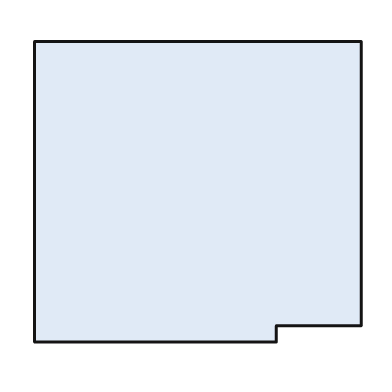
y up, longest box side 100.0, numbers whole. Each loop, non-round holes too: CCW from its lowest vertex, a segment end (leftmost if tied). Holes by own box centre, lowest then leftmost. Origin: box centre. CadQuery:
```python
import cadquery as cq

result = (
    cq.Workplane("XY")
    .moveTo(-50.0, -46.0)
    .lineTo(24.0, -46.0)
    .lineTo(24.0, -41.0)
    .lineTo(50.0, -41.0)
    .lineTo(50.0, 46.0)
    .lineTo(-50.0, 46.0)
    .close()
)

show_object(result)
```